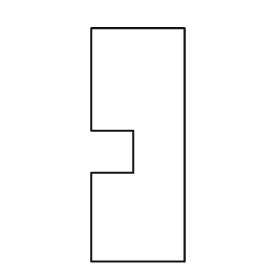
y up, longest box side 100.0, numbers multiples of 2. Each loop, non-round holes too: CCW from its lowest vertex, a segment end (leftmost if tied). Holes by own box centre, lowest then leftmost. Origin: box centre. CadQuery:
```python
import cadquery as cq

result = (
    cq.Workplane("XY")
    .moveTo(-20.0, -50.0)
    .lineTo(20.0, -50.0)
    .lineTo(20.0, 50.0)
    .lineTo(-20.0, 50.0)
    .lineTo(-20.0, 6.0)
    .lineTo(-2.0, 6.0)
    .lineTo(-2.0, -12.0)
    .lineTo(-20.0, -12.0)
    .close()
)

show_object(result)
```